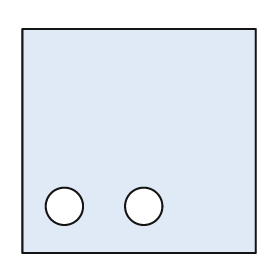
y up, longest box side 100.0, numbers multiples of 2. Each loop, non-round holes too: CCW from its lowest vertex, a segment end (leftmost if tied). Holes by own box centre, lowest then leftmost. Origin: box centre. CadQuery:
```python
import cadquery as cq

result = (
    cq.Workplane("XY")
    .moveTo(-50.0, -48.0)
    .lineTo(50.0, -48.0)
    .lineTo(50.0, 48.0)
    .lineTo(-50.0, 48.0)
    .close()
    .moveTo(-32.0, -28.0)
    .circle(8.0)
    .moveTo(2.0, -28.0)
    .circle(8.0)
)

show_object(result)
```